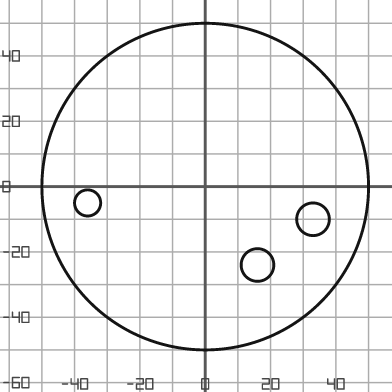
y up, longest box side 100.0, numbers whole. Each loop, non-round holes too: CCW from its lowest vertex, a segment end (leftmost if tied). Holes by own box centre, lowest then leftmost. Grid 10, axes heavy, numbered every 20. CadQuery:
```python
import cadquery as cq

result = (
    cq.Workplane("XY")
    .moveTo(0.0, 0.0)
    .circle(50.0)
    .moveTo(16.0, -24.0)
    .circle(5.0)
    .moveTo(33.0, -10.0)
    .circle(5.0)
    .moveTo(-36.0, -5.0)
    .circle(4.0)
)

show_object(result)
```